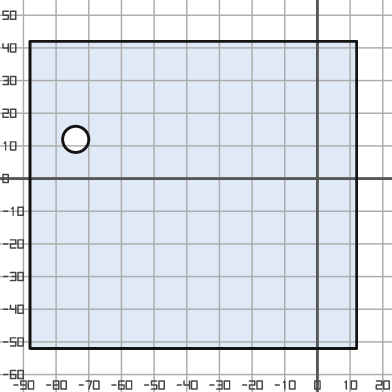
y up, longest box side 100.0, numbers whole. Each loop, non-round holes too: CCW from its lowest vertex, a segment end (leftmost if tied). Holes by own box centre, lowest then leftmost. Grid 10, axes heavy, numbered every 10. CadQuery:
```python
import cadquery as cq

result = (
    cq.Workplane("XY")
    .moveTo(-88.0, -52.0)
    .lineTo(12.0, -52.0)
    .lineTo(12.0, 42.0)
    .lineTo(-88.0, 42.0)
    .close()
    .moveTo(-74.0, 12.0)
    .circle(4.0)
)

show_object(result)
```